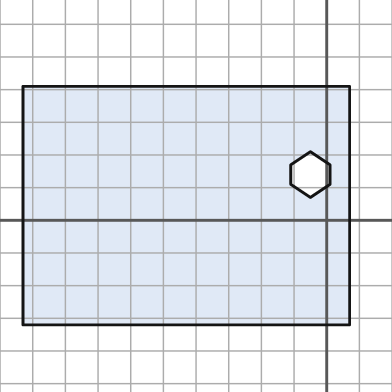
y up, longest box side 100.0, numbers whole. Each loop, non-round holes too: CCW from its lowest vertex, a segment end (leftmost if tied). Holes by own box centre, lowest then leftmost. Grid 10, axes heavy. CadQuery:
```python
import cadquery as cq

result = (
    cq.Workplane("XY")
    .moveTo(-93.0, -32.0)
    .lineTo(7.0, -32.0)
    .lineTo(7.0, 41.0)
    .lineTo(-93.0, 41.0)
    .close()
    .moveTo(-5.0, 7.0)
    .lineTo(1.0, 11.0)
    .lineTo(1.0, 17.0)
    .lineTo(-5.0, 21.0)
    .lineTo(-11.0, 17.0)
    .lineTo(-11.0, 11.0)
    .close()
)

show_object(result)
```